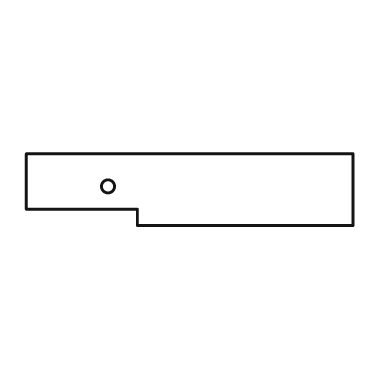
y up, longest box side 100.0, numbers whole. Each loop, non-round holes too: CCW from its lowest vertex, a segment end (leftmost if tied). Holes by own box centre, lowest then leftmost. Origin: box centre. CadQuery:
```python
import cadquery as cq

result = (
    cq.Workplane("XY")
    .moveTo(-16.0, -11.0)
    .lineTo(50.0, -11.0)
    .lineTo(50.0, 11.0)
    .lineTo(-50.0, 11.0)
    .lineTo(-50.0, -6.0)
    .lineTo(-16.0, -6.0)
    .close()
    .moveTo(-25.0, 1.0)
    .circle(2.0)
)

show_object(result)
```